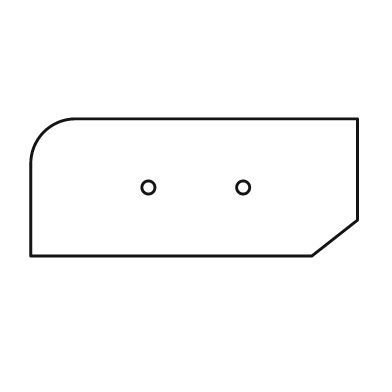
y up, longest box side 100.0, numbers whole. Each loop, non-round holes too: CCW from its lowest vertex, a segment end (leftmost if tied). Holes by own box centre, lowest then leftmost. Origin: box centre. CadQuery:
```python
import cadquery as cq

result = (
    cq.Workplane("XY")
    .moveTo(-50.0, -21.0)
    .lineTo(36.0, -21.0)
    .lineTo(50.0, -10.0)
    .lineTo(50.0, 21.0)
    .lineTo(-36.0, 21.0)
    .threePointArc((-46.0, 17.0), (-50.0, 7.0))
    .close()
    .moveTo(-14.0, 0.0)
    .circle(2.0)
    .moveTo(15.0, 0.0)
    .circle(2.0)
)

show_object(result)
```